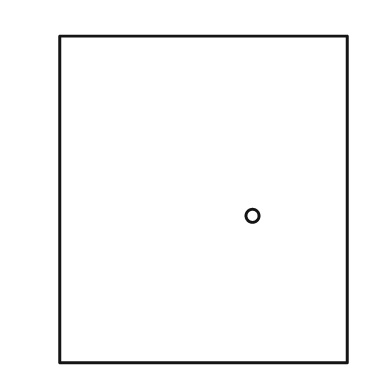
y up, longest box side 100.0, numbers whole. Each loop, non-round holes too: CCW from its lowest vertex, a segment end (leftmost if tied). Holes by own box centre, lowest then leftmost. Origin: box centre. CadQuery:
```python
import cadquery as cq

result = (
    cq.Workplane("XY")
    .moveTo(-44.0, -50.0)
    .lineTo(44.0, -50.0)
    .lineTo(44.0, 50.0)
    .lineTo(-44.0, 50.0)
    .close()
    .moveTo(15.0, -5.0)
    .circle(2.0)
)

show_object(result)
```